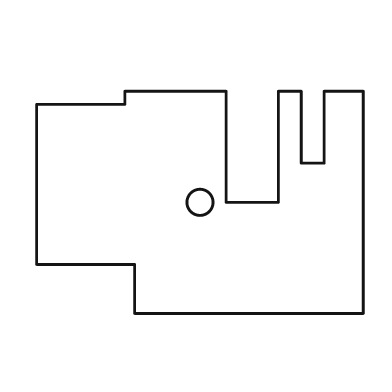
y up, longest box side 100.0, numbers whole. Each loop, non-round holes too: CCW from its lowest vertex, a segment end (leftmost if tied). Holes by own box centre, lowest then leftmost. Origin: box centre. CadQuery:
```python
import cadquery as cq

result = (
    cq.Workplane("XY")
    .moveTo(-20.0, -34.0)
    .lineTo(50.0, -34.0)
    .lineTo(50.0, 34.0)
    .lineTo(38.0, 34.0)
    .lineTo(38.0, 12.0)
    .lineTo(31.0, 12.0)
    .lineTo(31.0, 34.0)
    .lineTo(24.0, 34.0)
    .lineTo(24.0, 0.0)
    .lineTo(8.0, 0.0)
    .lineTo(8.0, 34.0)
    .lineTo(-23.0, 34.0)
    .lineTo(-23.0, 30.0)
    .lineTo(-50.0, 30.0)
    .lineTo(-50.0, -19.0)
    .lineTo(-20.0, -19.0)
    .close()
    .moveTo(0.0, 0.0)
    .circle(4.0)
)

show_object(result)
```